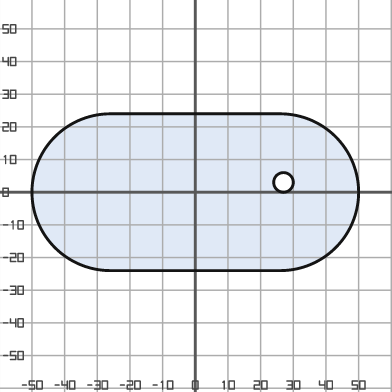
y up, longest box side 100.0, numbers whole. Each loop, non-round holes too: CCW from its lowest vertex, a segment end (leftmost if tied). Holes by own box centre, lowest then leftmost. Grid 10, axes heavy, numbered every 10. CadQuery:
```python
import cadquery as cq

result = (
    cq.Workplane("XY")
    .moveTo(-26.0, -24.0)
    .lineTo(26.0, -24.0)
    .threePointArc((50.0, 0.0), (26.0, 24.0))
    .lineTo(-26.0, 24.0)
    .threePointArc((-50.0, 0.0), (-26.0, -24.0))
    .close()
    .moveTo(27.0, 3.0)
    .circle(3.0)
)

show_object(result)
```